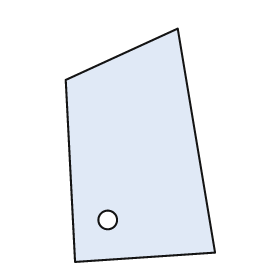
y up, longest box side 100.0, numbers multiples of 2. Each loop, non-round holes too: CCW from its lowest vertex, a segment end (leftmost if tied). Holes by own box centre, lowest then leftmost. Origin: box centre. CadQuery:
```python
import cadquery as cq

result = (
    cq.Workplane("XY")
    .moveTo(-28.0, -50.0)
    .lineTo(32.0, -46.0)
    .lineTo(16.0, 50.0)
    .lineTo(-32.0, 28.0)
    .close()
    .moveTo(-14.0, -32.0)
    .circle(4.0)
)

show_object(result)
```